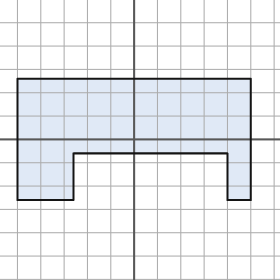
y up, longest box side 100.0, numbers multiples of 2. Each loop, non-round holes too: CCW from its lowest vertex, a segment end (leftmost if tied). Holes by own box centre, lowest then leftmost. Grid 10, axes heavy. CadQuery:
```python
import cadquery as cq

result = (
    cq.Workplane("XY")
    .moveTo(-50.0, -26.0)
    .lineTo(-26.0, -26.0)
    .lineTo(-26.0, -6.0)
    .lineTo(40.0, -6.0)
    .lineTo(40.0, -26.0)
    .lineTo(50.0, -26.0)
    .lineTo(50.0, 26.0)
    .lineTo(-50.0, 26.0)
    .close()
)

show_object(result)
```